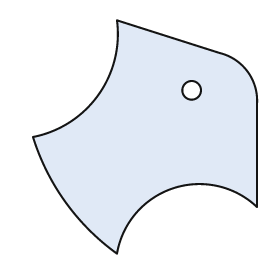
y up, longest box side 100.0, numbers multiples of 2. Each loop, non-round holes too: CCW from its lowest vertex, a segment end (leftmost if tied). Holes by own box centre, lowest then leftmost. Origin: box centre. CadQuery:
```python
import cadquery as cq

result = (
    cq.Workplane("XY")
    .moveTo(-12.0, -50.0)
    .threePointArc((12.0, -22.0), (48.0, -30.0))
    .lineTo(48.0, 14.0)
    .threePointArc((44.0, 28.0), (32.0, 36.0))
    .lineTo(-12.0, 50.0)
    .threePointArc((-20.0, 18.0), (-48.0, 0.0))
    .threePointArc((-34.0, -28.0), (-12.0, -50.0))
    .close()
    .moveTo(20.0, 20.0)
    .circle(4.0)
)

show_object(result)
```